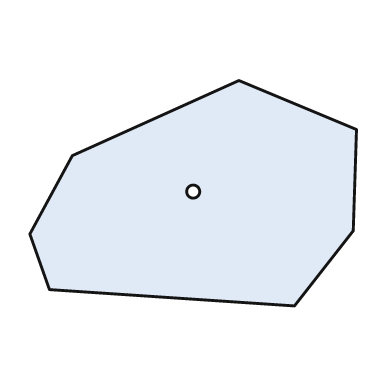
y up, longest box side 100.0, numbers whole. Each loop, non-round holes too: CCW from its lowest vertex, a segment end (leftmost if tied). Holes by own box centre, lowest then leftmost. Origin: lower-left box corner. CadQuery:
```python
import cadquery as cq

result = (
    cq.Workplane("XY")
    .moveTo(81.0, 0.0)
    .lineTo(99.0, 23.0)
    .lineTo(100.0, 54.0)
    .lineTo(64.0, 69.0)
    .lineTo(13.0, 46.0)
    .lineTo(0.0, 22.0)
    .lineTo(6.0, 5.0)
    .close()
    .moveTo(50.0, 35.0)
    .circle(2.0)
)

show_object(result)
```